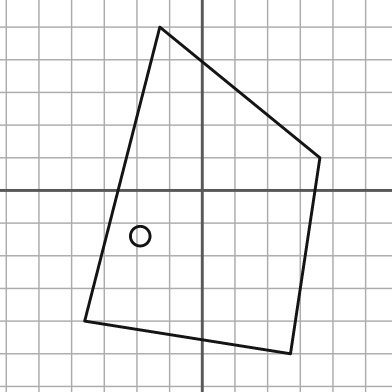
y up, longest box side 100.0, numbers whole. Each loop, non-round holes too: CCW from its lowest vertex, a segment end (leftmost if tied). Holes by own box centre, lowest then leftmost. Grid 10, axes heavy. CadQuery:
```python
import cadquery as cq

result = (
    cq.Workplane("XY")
    .moveTo(27.0, -50.0)
    .lineTo(36.0, 10.0)
    .lineTo(-13.0, 50.0)
    .lineTo(-36.0, -40.0)
    .close()
    .moveTo(-19.0, -14.0)
    .circle(3.0)
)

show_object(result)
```